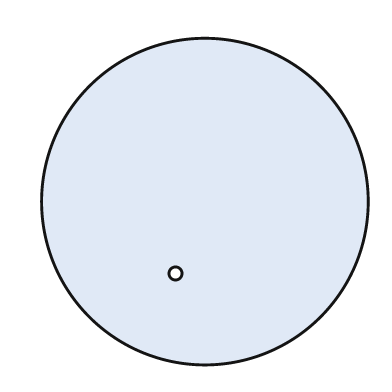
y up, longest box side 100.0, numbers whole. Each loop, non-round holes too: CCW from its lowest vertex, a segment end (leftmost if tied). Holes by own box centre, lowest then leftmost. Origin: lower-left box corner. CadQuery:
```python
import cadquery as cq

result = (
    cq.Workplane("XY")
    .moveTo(50.0, 50.0)
    .circle(50.0)
    .moveTo(41.0, 28.0)
    .circle(2.0)
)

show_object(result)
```